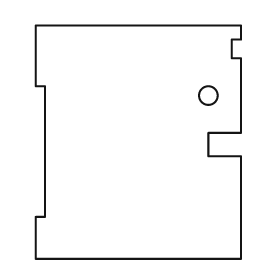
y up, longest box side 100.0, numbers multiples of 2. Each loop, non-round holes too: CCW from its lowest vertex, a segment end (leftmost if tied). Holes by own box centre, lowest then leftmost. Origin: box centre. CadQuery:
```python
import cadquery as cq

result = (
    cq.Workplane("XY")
    .moveTo(-44.0, -50.0)
    .lineTo(44.0, -50.0)
    .lineTo(44.0, -6.0)
    .lineTo(30.0, -6.0)
    .lineTo(30.0, 4.0)
    .lineTo(44.0, 4.0)
    .lineTo(44.0, 36.0)
    .lineTo(40.0, 36.0)
    .lineTo(40.0, 44.0)
    .lineTo(44.0, 44.0)
    .lineTo(44.0, 50.0)
    .lineTo(-44.0, 50.0)
    .lineTo(-44.0, 24.0)
    .lineTo(-40.0, 24.0)
    .lineTo(-40.0, -32.0)
    .lineTo(-44.0, -32.0)
    .close()
    .moveTo(30.0, 20.0)
    .circle(4.0)
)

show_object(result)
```